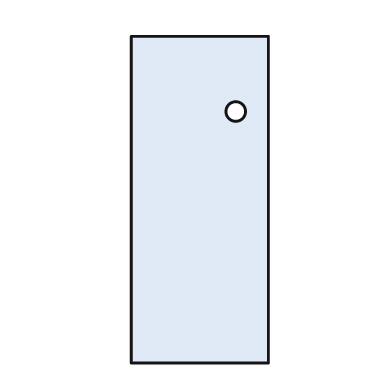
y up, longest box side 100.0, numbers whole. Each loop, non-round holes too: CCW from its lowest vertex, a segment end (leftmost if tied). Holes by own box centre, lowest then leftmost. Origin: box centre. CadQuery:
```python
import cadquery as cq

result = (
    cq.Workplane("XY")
    .moveTo(-21.0, -50.0)
    .lineTo(21.0, -50.0)
    .lineTo(21.0, 50.0)
    .lineTo(-21.0, 50.0)
    .close()
    .moveTo(11.0, 27.0)
    .circle(3.0)
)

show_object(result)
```